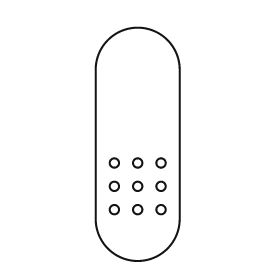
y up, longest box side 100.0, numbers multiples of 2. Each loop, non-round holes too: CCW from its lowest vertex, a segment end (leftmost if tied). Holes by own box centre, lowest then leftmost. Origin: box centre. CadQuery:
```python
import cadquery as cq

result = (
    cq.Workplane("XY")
    .moveTo(-18.0, -32.0)
    .threePointArc((0.0, -50.0), (18.0, -32.0))
    .lineTo(18.0, 32.0)
    .threePointArc((0.0, 50.0), (-18.0, 32.0))
    .close()
    .moveTo(-10.0, -28.0)
    .circle(2.0)
    .moveTo(0.0, -28.0)
    .circle(2.0)
    .moveTo(10.0, -28.0)
    .circle(2.0)
    .moveTo(-10.0, -18.0)
    .circle(2.0)
    .moveTo(0.0, -18.0)
    .circle(2.0)
    .moveTo(10.0, -18.0)
    .circle(2.0)
    .moveTo(-10.0, -8.0)
    .circle(2.0)
    .moveTo(0.0, -8.0)
    .circle(2.0)
    .moveTo(10.0, -8.0)
    .circle(2.0)
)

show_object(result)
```